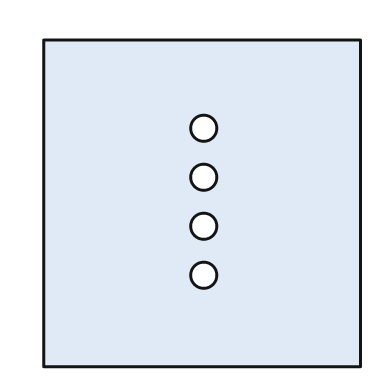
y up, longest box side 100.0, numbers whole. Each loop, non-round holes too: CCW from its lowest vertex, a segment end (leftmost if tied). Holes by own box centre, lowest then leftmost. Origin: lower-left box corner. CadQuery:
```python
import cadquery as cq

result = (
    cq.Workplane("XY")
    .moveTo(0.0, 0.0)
    .lineTo(97.0, 0.0)
    .lineTo(97.0, 100.0)
    .lineTo(0.0, 100.0)
    .close()
    .moveTo(49.0, 28.0)
    .circle(4.0)
    .moveTo(49.0, 43.0)
    .circle(4.0)
    .moveTo(49.0, 58.0)
    .circle(4.0)
    .moveTo(49.0, 73.0)
    .circle(4.0)
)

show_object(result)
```